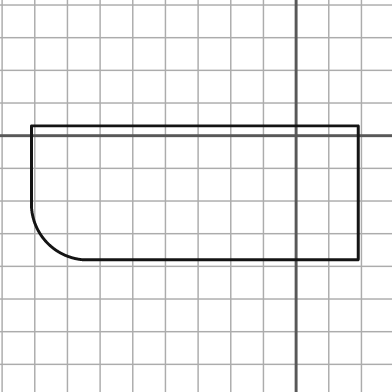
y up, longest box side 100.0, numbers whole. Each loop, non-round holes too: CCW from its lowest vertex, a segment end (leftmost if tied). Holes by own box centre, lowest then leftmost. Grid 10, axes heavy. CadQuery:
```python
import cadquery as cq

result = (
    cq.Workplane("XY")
    .moveTo(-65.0, -38.0)
    .lineTo(19.0, -38.0)
    .lineTo(19.0, 3.0)
    .lineTo(-81.0, 3.0)
    .lineTo(-81.0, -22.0)
    .threePointArc((-76.0, -33.0), (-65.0, -38.0))
    .close()
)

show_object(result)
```